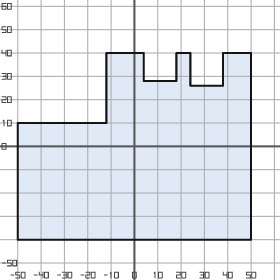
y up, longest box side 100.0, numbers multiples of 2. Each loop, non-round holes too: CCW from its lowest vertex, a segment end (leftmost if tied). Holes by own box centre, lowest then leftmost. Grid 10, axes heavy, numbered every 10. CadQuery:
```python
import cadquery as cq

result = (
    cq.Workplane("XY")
    .moveTo(-50.0, -40.0)
    .lineTo(50.0, -40.0)
    .lineTo(50.0, 40.0)
    .lineTo(38.0, 40.0)
    .lineTo(38.0, 26.0)
    .lineTo(24.0, 26.0)
    .lineTo(24.0, 40.0)
    .lineTo(18.0, 40.0)
    .lineTo(18.0, 28.0)
    .lineTo(4.0, 28.0)
    .lineTo(4.0, 40.0)
    .lineTo(-12.0, 40.0)
    .lineTo(-12.0, 10.0)
    .lineTo(-50.0, 10.0)
    .close()
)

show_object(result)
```